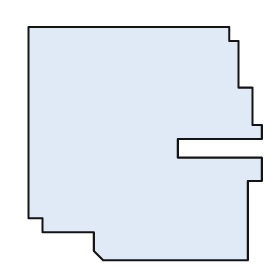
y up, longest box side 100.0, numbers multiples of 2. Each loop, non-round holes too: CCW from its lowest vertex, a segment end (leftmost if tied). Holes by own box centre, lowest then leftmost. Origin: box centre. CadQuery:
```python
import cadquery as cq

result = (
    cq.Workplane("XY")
    .moveTo(-18.0, -50.0)
    .lineTo(44.0, -50.0)
    .lineTo(44.0, -16.0)
    .lineTo(50.0, -16.0)
    .lineTo(50.0, -6.0)
    .lineTo(14.0, -6.0)
    .lineTo(14.0, 2.0)
    .lineTo(50.0, 2.0)
    .lineTo(50.0, 8.0)
    .lineTo(46.0, 8.0)
    .lineTo(46.0, 24.0)
    .lineTo(40.0, 24.0)
    .lineTo(40.0, 44.0)
    .lineTo(36.0, 44.0)
    .lineTo(36.0, 50.0)
    .lineTo(-50.0, 50.0)
    .lineTo(-50.0, -32.0)
    .lineTo(-44.0, -32.0)
    .lineTo(-44.0, -38.0)
    .lineTo(-22.0, -38.0)
    .lineTo(-22.0, -46.0)
    .close()
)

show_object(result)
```